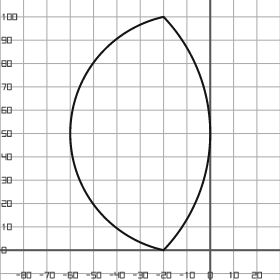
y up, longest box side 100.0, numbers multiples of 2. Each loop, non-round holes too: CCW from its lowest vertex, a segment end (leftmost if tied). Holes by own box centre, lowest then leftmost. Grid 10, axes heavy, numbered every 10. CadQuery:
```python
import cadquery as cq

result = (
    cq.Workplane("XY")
    .moveTo(-20.0, 0.0)
    .threePointArc((0.0, 50.0), (-20.0, 100.0))
    .threePointArc((-60.0, 50.0), (-20.0, 0.0))
    .close()
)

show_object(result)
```